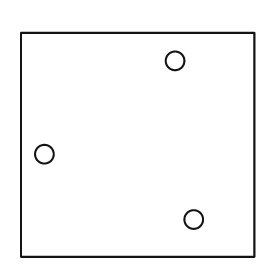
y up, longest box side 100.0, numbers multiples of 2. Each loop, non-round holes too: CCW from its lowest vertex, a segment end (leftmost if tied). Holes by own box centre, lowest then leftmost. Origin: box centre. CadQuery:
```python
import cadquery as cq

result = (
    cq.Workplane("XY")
    .moveTo(-50.0, -48.0)
    .lineTo(50.0, -48.0)
    .lineTo(50.0, 48.0)
    .lineTo(-50.0, 48.0)
    .close()
    .moveTo(24.0, -32.0)
    .circle(4.0)
    .moveTo(-40.0, -4.0)
    .circle(4.0)
    .moveTo(16.0, 36.0)
    .circle(4.0)
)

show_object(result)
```